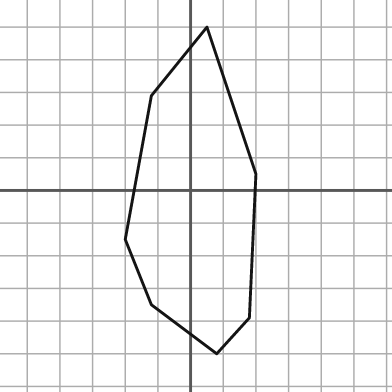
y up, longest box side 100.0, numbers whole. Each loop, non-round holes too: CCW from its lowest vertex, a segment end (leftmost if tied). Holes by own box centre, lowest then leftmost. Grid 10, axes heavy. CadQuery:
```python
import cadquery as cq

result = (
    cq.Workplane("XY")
    .moveTo(8.0, -50.0)
    .lineTo(18.0, -39.0)
    .lineTo(20.0, 5.0)
    .lineTo(5.0, 50.0)
    .lineTo(-12.0, 29.0)
    .lineTo(-20.0, -15.0)
    .lineTo(-12.0, -35.0)
    .close()
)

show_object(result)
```